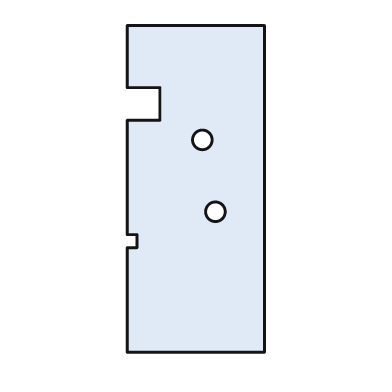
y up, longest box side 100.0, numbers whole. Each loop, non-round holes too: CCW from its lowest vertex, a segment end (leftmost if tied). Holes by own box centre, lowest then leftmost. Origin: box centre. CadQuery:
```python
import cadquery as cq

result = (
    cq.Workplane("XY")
    .moveTo(-21.0, -50.0)
    .lineTo(21.0, -50.0)
    .lineTo(21.0, 50.0)
    .lineTo(-21.0, 50.0)
    .lineTo(-21.0, 31.0)
    .lineTo(-11.0, 31.0)
    .lineTo(-11.0, 21.0)
    .lineTo(-21.0, 21.0)
    .lineTo(-21.0, -14.0)
    .lineTo(-18.0, -14.0)
    .lineTo(-18.0, -18.0)
    .lineTo(-21.0, -18.0)
    .close()
    .moveTo(6.0, -7.0)
    .circle(3.0)
    .moveTo(2.0, 15.0)
    .circle(3.0)
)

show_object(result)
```